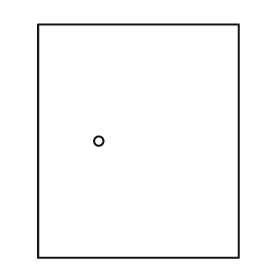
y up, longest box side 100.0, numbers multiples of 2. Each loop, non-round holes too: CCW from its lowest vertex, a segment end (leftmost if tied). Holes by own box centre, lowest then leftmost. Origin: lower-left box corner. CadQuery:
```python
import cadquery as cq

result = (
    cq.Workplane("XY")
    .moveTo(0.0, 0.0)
    .lineTo(86.0, 0.0)
    .lineTo(86.0, 100.0)
    .lineTo(0.0, 100.0)
    .close()
    .moveTo(26.0, 50.0)
    .circle(2.0)
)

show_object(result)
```